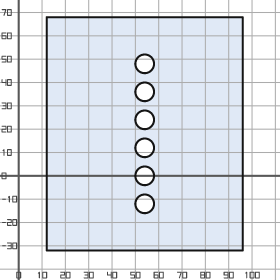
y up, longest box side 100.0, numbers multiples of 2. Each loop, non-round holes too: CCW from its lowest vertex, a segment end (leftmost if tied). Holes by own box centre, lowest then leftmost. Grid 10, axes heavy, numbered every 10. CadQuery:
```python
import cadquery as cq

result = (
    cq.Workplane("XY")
    .moveTo(12.0, -32.0)
    .lineTo(96.0, -32.0)
    .lineTo(96.0, 68.0)
    .lineTo(12.0, 68.0)
    .close()
    .moveTo(54.0, -12.0)
    .circle(4.0)
    .moveTo(54.0, 0.0)
    .circle(4.0)
    .moveTo(54.0, 12.0)
    .circle(4.0)
    .moveTo(54.0, 24.0)
    .circle(4.0)
    .moveTo(54.0, 36.0)
    .circle(4.0)
    .moveTo(54.0, 48.0)
    .circle(4.0)
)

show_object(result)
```